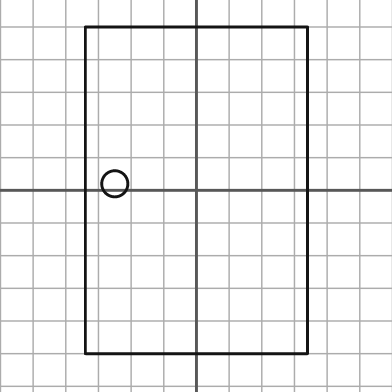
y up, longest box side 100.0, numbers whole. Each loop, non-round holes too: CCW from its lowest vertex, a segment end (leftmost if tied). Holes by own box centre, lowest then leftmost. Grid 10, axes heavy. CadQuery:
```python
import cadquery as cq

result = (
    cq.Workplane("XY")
    .moveTo(-34.0, -50.0)
    .lineTo(34.0, -50.0)
    .lineTo(34.0, 50.0)
    .lineTo(-34.0, 50.0)
    .close()
    .moveTo(-25.0, 2.0)
    .circle(4.0)
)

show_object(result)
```